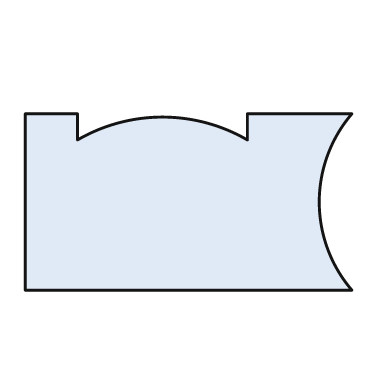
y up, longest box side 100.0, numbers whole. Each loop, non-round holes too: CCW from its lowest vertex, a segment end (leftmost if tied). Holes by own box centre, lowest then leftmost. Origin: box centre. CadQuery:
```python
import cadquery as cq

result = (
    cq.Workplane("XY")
    .moveTo(-50.0, -27.0)
    .lineTo(50.0, -27.0)
    .threePointArc((40.0, 0.0), (50.0, 27.0))
    .lineTo(18.0, 27.0)
    .lineTo(18.0, 19.0)
    .threePointArc((-8.0, 26.0), (-34.0, 19.0))
    .lineTo(-34.0, 27.0)
    .lineTo(-50.0, 27.0)
    .close()
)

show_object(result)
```